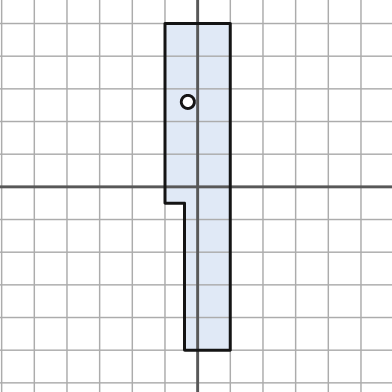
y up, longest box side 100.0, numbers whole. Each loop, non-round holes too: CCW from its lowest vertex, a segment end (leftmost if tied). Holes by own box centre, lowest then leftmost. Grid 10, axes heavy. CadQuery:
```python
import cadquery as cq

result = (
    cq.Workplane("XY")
    .moveTo(-4.0, -50.0)
    .lineTo(10.0, -50.0)
    .lineTo(10.0, 50.0)
    .lineTo(-10.0, 50.0)
    .lineTo(-10.0, -5.0)
    .lineTo(-4.0, -5.0)
    .close()
    .moveTo(-3.0, 26.0)
    .circle(2.0)
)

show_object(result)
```